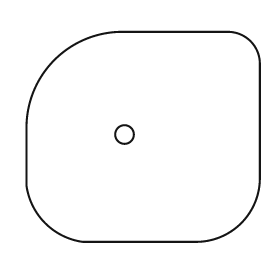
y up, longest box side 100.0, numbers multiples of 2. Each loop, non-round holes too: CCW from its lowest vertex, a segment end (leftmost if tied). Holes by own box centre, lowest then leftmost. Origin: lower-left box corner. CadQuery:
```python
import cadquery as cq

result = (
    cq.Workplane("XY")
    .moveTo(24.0, 0.0)
    .lineTo(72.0, 0.0)
    .threePointArc((92.0, 8.0), (100.0, 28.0))
    .lineTo(100.0, 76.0)
    .threePointArc((96.0, 86.0), (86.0, 90.0))
    .lineTo(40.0, 90.0)
    .threePointArc((12.0, 78.0), (0.0, 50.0))
    .lineTo(0.0, 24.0)
    .threePointArc((8.0, 8.0), (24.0, 0.0))
    .close()
    .moveTo(42.0, 46.0)
    .circle(4.0)
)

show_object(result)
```